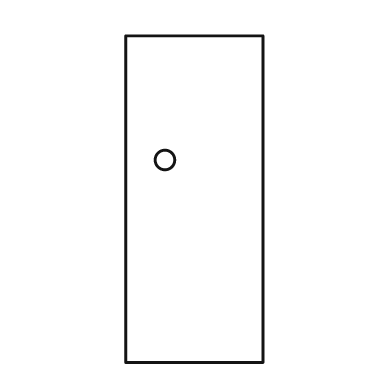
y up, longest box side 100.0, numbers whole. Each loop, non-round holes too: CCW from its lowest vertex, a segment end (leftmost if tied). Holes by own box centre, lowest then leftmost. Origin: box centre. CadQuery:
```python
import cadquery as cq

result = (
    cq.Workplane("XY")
    .moveTo(-21.0, -50.0)
    .lineTo(21.0, -50.0)
    .lineTo(21.0, 50.0)
    .lineTo(-21.0, 50.0)
    .close()
    .moveTo(-9.0, 12.0)
    .circle(3.0)
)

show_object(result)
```